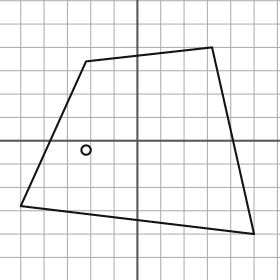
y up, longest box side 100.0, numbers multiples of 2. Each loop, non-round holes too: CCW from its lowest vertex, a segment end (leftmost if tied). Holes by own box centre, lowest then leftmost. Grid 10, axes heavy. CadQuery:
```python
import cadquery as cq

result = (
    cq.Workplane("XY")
    .moveTo(50.0, -40.0)
    .lineTo(32.0, 40.0)
    .lineTo(-22.0, 34.0)
    .lineTo(-50.0, -28.0)
    .close()
    .moveTo(-22.0, -4.0)
    .circle(2.0)
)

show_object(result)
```